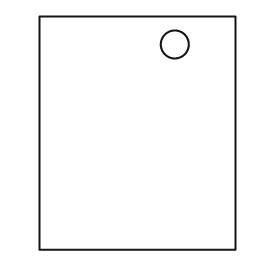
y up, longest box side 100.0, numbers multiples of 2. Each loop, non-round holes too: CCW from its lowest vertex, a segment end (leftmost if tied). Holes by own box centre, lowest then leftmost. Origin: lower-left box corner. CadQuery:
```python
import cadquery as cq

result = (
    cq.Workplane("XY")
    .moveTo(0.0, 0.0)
    .lineTo(84.0, 0.0)
    .lineTo(84.0, 100.0)
    .lineTo(0.0, 100.0)
    .close()
    .moveTo(58.0, 88.0)
    .circle(6.0)
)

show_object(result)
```